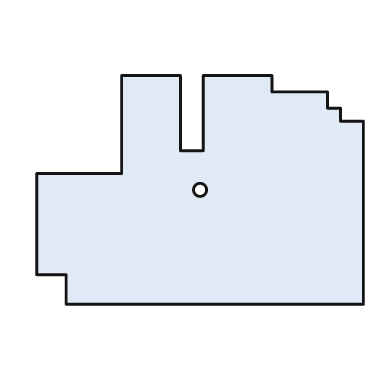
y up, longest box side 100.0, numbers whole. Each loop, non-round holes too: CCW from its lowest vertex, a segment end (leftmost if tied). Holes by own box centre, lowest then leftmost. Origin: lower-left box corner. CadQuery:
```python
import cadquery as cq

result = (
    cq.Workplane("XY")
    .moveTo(9.0, 0.0)
    .lineTo(100.0, 0.0)
    .lineTo(100.0, 56.0)
    .lineTo(93.0, 56.0)
    .lineTo(93.0, 60.0)
    .lineTo(89.0, 60.0)
    .lineTo(89.0, 65.0)
    .lineTo(72.0, 65.0)
    .lineTo(72.0, 70.0)
    .lineTo(51.0, 70.0)
    .lineTo(51.0, 47.0)
    .lineTo(44.0, 47.0)
    .lineTo(44.0, 70.0)
    .lineTo(26.0, 70.0)
    .lineTo(26.0, 40.0)
    .lineTo(0.0, 40.0)
    .lineTo(0.0, 9.0)
    .lineTo(9.0, 9.0)
    .close()
    .moveTo(50.0, 35.0)
    .circle(2.0)
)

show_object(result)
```